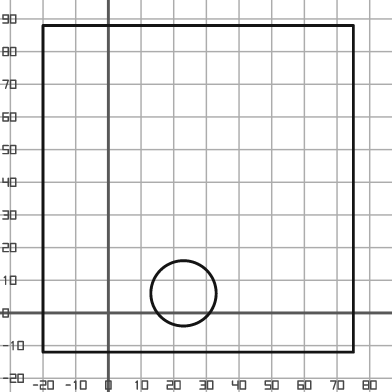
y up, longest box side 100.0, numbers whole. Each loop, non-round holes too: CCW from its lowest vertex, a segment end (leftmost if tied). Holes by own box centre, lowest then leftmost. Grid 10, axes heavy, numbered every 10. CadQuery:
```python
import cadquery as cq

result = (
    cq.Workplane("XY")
    .moveTo(-20.0, -12.0)
    .lineTo(75.0, -12.0)
    .lineTo(75.0, 88.0)
    .lineTo(-20.0, 88.0)
    .close()
    .moveTo(23.0, 6.0)
    .circle(10.0)
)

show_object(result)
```